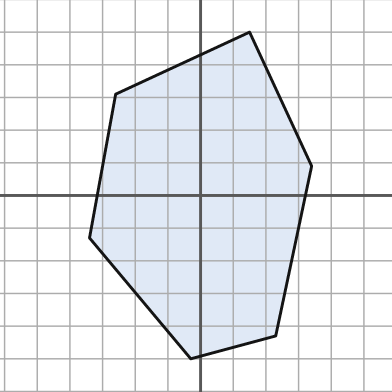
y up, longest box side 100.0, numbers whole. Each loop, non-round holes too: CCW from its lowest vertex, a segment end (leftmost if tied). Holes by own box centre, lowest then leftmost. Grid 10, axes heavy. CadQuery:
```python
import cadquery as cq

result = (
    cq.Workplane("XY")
    .moveTo(-3.0, -50.0)
    .lineTo(23.0, -43.0)
    .lineTo(34.0, 9.0)
    .lineTo(15.0, 50.0)
    .lineTo(-26.0, 31.0)
    .lineTo(-34.0, -13.0)
    .close()
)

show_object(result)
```